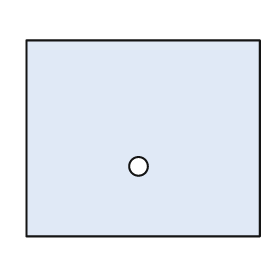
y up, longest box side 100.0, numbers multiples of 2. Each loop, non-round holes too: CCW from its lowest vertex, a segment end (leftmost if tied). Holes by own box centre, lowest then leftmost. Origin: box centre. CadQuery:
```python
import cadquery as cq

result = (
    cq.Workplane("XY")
    .moveTo(-50.0, -42.0)
    .lineTo(50.0, -42.0)
    .lineTo(50.0, 42.0)
    .lineTo(-50.0, 42.0)
    .close()
    .moveTo(-2.0, -12.0)
    .circle(4.0)
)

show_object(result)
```